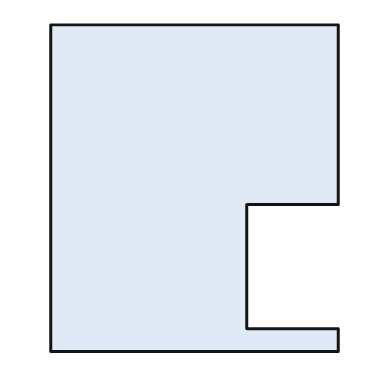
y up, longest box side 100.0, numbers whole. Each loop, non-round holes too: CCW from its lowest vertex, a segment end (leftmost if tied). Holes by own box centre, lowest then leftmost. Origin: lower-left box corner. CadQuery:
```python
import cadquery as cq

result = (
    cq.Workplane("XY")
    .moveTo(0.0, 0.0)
    .lineTo(88.0, 0.0)
    .lineTo(88.0, 7.0)
    .lineTo(60.0, 7.0)
    .lineTo(60.0, 45.0)
    .lineTo(88.0, 45.0)
    .lineTo(88.0, 100.0)
    .lineTo(0.0, 100.0)
    .close()
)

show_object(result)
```